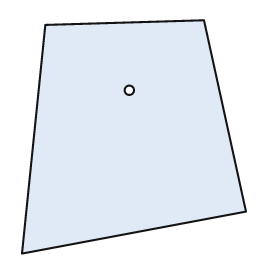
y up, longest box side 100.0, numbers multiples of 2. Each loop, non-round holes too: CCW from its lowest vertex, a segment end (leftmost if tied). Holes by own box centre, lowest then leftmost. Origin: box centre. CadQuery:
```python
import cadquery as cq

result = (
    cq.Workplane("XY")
    .moveTo(-48.0, -50.0)
    .lineTo(48.0, -32.0)
    .lineTo(30.0, 50.0)
    .lineTo(-38.0, 48.0)
    .close()
    .moveTo(-2.0, 20.0)
    .circle(2.0)
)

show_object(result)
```